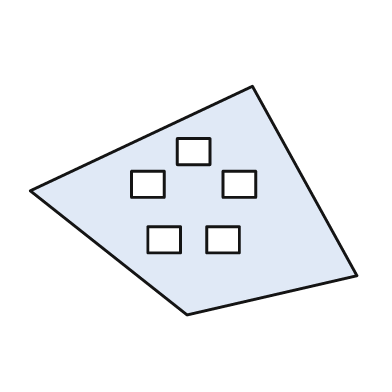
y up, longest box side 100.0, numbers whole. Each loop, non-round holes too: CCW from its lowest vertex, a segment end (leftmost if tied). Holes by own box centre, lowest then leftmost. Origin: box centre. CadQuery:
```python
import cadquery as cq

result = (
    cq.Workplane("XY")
    .moveTo(-2.0, -35.0)
    .lineTo(50.0, -23.0)
    .lineTo(18.0, 35.0)
    .lineTo(-50.0, 3.0)
    .close()
    .moveTo(-14.0, -16.0)
    .lineTo(-4.0, -16.0)
    .lineTo(-4.0, -8.0)
    .lineTo(-14.0, -8.0)
    .close()
    .moveTo(4.0, -16.0)
    .lineTo(14.0, -16.0)
    .lineTo(14.0, -8.0)
    .lineTo(4.0, -8.0)
    .close()
    .moveTo(-19.0, 1.0)
    .lineTo(-9.0, 1.0)
    .lineTo(-9.0, 9.0)
    .lineTo(-19.0, 9.0)
    .close()
    .moveTo(9.0, 1.0)
    .lineTo(19.0, 1.0)
    .lineTo(19.0, 9.0)
    .lineTo(9.0, 9.0)
    .close()
    .moveTo(-5.0, 11.0)
    .lineTo(5.0, 11.0)
    .lineTo(5.0, 19.0)
    .lineTo(-5.0, 19.0)
    .close()
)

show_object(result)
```